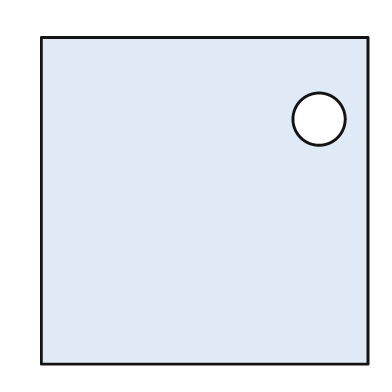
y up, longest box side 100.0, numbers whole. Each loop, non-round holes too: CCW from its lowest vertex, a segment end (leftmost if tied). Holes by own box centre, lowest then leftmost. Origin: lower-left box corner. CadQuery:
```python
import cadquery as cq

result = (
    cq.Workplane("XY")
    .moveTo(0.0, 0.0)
    .lineTo(100.0, 0.0)
    .lineTo(100.0, 100.0)
    .lineTo(0.0, 100.0)
    .close()
    .moveTo(85.0, 75.0)
    .circle(8.0)
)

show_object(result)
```